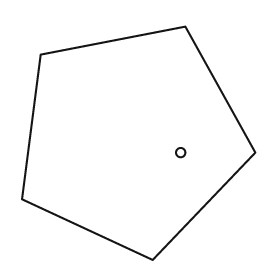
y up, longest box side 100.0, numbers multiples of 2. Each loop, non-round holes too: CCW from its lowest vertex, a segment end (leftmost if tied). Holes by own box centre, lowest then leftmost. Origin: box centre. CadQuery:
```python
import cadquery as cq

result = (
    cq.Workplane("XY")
    .moveTo(6.0, -50.0)
    .lineTo(50.0, -4.0)
    .lineTo(20.0, 50.0)
    .lineTo(-42.0, 38.0)
    .lineTo(-50.0, -24.0)
    .close()
    .moveTo(18.0, -4.0)
    .circle(2.0)
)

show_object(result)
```